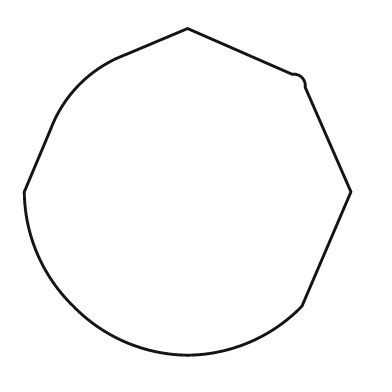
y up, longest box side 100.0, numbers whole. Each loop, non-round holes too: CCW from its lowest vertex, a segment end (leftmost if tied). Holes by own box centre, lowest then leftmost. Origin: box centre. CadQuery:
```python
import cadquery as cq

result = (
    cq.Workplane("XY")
    .moveTo(0.0, -50.0)
    .threePointArc((19.0, -46.0), (35.0, -35.0))
    .lineTo(50.0, 0.0)
    .lineTo(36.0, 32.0)
    .threePointArc((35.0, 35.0), (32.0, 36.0))
    .lineTo(0.0, 50.0)
    .lineTo(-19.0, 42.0)
    .threePointArc((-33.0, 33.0), (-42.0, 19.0))
    .lineTo(-50.0, 0.0)
    .threePointArc((-46.0, -19.0), (-35.0, -35.0))
    .threePointArc((-19.0, -46.0), (0.0, -50.0))
    .close()
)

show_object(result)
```